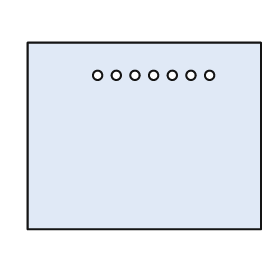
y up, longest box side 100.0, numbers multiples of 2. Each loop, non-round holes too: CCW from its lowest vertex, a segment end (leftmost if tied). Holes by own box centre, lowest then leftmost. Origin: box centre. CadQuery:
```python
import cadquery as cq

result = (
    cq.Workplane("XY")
    .moveTo(-50.0, -40.0)
    .lineTo(50.0, -40.0)
    .lineTo(50.0, 40.0)
    .lineTo(-50.0, 40.0)
    .close()
    .moveTo(-20.0, 26.0)
    .circle(2.0)
    .moveTo(-12.0, 26.0)
    .circle(2.0)
    .moveTo(-4.0, 26.0)
    .circle(2.0)
    .moveTo(4.0, 26.0)
    .circle(2.0)
    .moveTo(12.0, 26.0)
    .circle(2.0)
    .moveTo(20.0, 26.0)
    .circle(2.0)
    .moveTo(28.0, 26.0)
    .circle(2.0)
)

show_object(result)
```